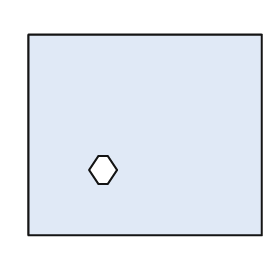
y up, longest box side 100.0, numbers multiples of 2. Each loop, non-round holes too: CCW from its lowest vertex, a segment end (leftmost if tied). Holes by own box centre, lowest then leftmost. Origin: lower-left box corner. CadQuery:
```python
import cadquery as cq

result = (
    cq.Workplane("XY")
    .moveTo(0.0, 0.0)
    .lineTo(100.0, 0.0)
    .lineTo(100.0, 86.0)
    .lineTo(0.0, 86.0)
    .close()
    .moveTo(30.0, 22.0)
    .lineTo(34.0, 22.0)
    .lineTo(38.0, 28.0)
    .lineTo(34.0, 34.0)
    .lineTo(30.0, 34.0)
    .lineTo(26.0, 28.0)
    .close()
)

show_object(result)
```